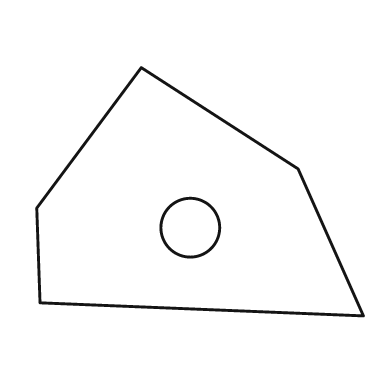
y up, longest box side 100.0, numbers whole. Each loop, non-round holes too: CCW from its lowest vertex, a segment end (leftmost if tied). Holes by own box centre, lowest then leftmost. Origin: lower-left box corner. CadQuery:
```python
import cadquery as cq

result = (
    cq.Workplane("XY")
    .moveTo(100.0, 0.0)
    .lineTo(80.0, 45.0)
    .lineTo(32.0, 76.0)
    .lineTo(0.0, 33.0)
    .lineTo(1.0, 4.0)
    .close()
    .moveTo(47.0, 27.0)
    .circle(9.0)
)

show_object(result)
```